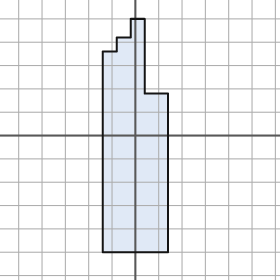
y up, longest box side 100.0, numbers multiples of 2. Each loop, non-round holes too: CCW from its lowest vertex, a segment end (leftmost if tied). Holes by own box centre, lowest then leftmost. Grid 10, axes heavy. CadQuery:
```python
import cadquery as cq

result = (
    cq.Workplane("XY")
    .moveTo(-14.0, -50.0)
    .lineTo(14.0, -50.0)
    .lineTo(14.0, 18.0)
    .lineTo(4.0, 18.0)
    .lineTo(4.0, 50.0)
    .lineTo(-2.0, 50.0)
    .lineTo(-2.0, 42.0)
    .lineTo(-8.0, 42.0)
    .lineTo(-8.0, 36.0)
    .lineTo(-14.0, 36.0)
    .close()
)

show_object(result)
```